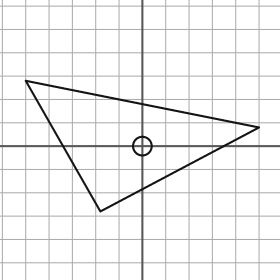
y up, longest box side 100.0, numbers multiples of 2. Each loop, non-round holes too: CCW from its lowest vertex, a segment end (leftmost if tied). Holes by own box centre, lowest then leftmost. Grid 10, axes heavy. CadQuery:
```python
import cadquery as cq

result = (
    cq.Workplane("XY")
    .moveTo(-18.0, -28.0)
    .lineTo(50.0, 8.0)
    .lineTo(-50.0, 28.0)
    .close()
    .moveTo(0.0, 0.0)
    .circle(4.0)
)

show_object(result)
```